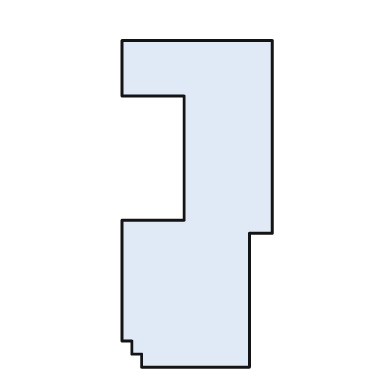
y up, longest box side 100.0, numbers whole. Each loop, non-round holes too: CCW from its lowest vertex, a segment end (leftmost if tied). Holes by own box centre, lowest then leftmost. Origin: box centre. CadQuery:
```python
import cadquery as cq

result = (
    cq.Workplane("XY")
    .moveTo(-17.0, -50.0)
    .lineTo(16.0, -50.0)
    .lineTo(16.0, -9.0)
    .lineTo(23.0, -9.0)
    .lineTo(23.0, 50.0)
    .lineTo(-23.0, 50.0)
    .lineTo(-23.0, 33.0)
    .lineTo(-4.0, 33.0)
    .lineTo(-4.0, -5.0)
    .lineTo(-23.0, -5.0)
    .lineTo(-23.0, -42.0)
    .lineTo(-20.0, -42.0)
    .lineTo(-20.0, -46.0)
    .lineTo(-17.0, -46.0)
    .close()
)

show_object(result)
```